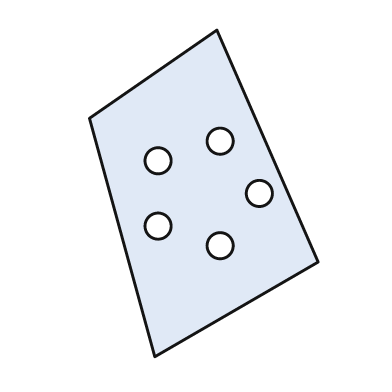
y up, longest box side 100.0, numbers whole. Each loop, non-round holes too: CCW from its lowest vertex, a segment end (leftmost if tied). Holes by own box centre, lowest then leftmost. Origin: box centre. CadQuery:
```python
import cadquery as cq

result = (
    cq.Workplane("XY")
    .moveTo(-15.0, -50.0)
    .lineTo(35.0, -21.0)
    .lineTo(4.0, 50.0)
    .lineTo(-35.0, 23.0)
    .close()
    .moveTo(5.0, -16.0)
    .circle(4.0)
    .moveTo(-14.0, -10.0)
    .circle(4.0)
    .moveTo(17.0, 0.0)
    .circle(4.0)
    .moveTo(-14.0, 10.0)
    .circle(4.0)
    .moveTo(5.0, 16.0)
    .circle(4.0)
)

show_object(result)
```